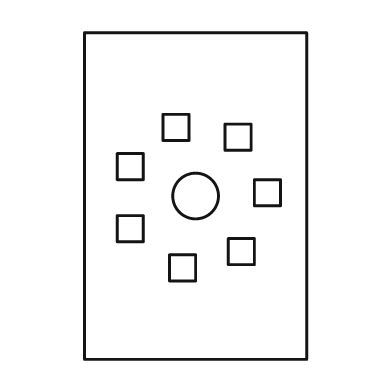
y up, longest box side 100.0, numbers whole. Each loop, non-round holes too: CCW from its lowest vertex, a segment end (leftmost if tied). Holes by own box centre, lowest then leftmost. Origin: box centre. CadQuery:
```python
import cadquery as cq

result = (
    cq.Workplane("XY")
    .moveTo(-34.0, -50.0)
    .lineTo(34.0, -50.0)
    .lineTo(34.0, 50.0)
    .lineTo(-34.0, 50.0)
    .close()
    .moveTo(-8.0, -26.0)
    .lineTo(0.0, -26.0)
    .lineTo(0.0, -18.0)
    .lineTo(-8.0, -18.0)
    .close()
    .moveTo(10.0, -21.0)
    .lineTo(18.0, -21.0)
    .lineTo(18.0, -13.0)
    .lineTo(10.0, -13.0)
    .close()
    .moveTo(-24.0, -14.0)
    .lineTo(-16.0, -14.0)
    .lineTo(-16.0, -6.0)
    .lineTo(-24.0, -6.0)
    .close()
    .moveTo(0.0, 0.0)
    .circle(7.0)
    .moveTo(18.0, -3.0)
    .lineTo(26.0, -3.0)
    .lineTo(26.0, 5.0)
    .lineTo(18.0, 5.0)
    .close()
    .moveTo(-24.0, 5.0)
    .lineTo(-16.0, 5.0)
    .lineTo(-16.0, 13.0)
    .lineTo(-24.0, 13.0)
    .close()
    .moveTo(9.0, 14.0)
    .lineTo(17.0, 14.0)
    .lineTo(17.0, 22.0)
    .lineTo(9.0, 22.0)
    .close()
    .moveTo(-10.0, 17.0)
    .lineTo(-2.0, 17.0)
    .lineTo(-2.0, 25.0)
    .lineTo(-10.0, 25.0)
    .close()
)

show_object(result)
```